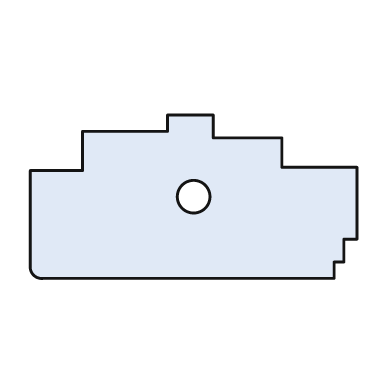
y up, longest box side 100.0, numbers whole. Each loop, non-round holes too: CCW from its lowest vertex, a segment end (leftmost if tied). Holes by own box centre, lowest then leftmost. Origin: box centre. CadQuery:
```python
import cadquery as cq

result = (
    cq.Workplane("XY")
    .moveTo(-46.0, -25.0)
    .lineTo(43.0, -25.0)
    .lineTo(43.0, -20.0)
    .lineTo(46.0, -20.0)
    .lineTo(46.0, -13.0)
    .lineTo(50.0, -13.0)
    .lineTo(50.0, 9.0)
    .lineTo(27.0, 9.0)
    .lineTo(27.0, 18.0)
    .lineTo(6.0, 18.0)
    .lineTo(6.0, 25.0)
    .lineTo(-8.0, 25.0)
    .lineTo(-8.0, 20.0)
    .lineTo(-34.0, 20.0)
    .lineTo(-34.0, 8.0)
    .lineTo(-50.0, 8.0)
    .lineTo(-50.0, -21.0)
    .threePointArc((-49.0, -24.0), (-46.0, -25.0))
    .close()
    .moveTo(0.0, 0.0)
    .circle(5.0)
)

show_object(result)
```